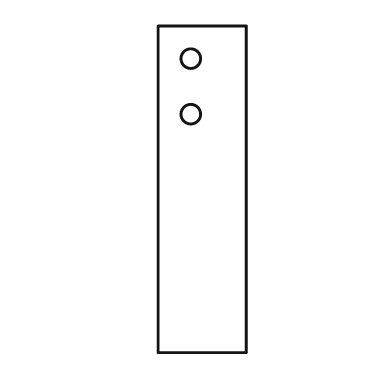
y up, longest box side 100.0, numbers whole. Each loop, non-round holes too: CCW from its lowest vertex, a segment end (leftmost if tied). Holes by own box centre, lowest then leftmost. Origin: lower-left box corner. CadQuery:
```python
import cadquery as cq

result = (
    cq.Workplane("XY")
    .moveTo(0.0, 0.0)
    .lineTo(27.0, 0.0)
    .lineTo(27.0, 100.0)
    .lineTo(0.0, 100.0)
    .close()
    .moveTo(10.0, 73.0)
    .circle(3.0)
    .moveTo(10.0, 90.0)
    .circle(3.0)
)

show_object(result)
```